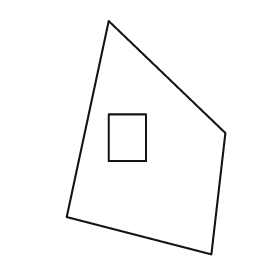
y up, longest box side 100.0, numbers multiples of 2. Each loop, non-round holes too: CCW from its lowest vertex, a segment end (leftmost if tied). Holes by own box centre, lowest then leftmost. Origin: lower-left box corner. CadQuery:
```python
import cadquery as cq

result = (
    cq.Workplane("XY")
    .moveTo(62.0, 0.0)
    .lineTo(68.0, 52.0)
    .lineTo(18.0, 100.0)
    .lineTo(0.0, 16.0)
    .close()
    .moveTo(18.0, 40.0)
    .lineTo(34.0, 40.0)
    .lineTo(34.0, 60.0)
    .lineTo(18.0, 60.0)
    .close()
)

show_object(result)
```